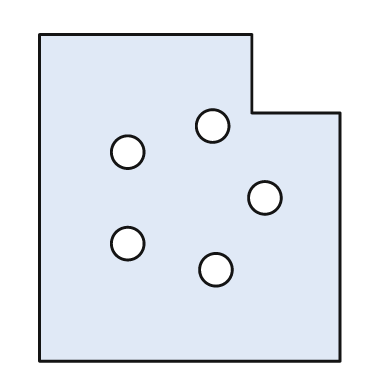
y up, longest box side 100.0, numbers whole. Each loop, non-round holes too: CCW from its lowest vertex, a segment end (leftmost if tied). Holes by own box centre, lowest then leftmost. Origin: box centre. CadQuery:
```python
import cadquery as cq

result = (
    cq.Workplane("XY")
    .moveTo(-46.0, -50.0)
    .lineTo(46.0, -50.0)
    .lineTo(46.0, 26.0)
    .lineTo(19.0, 26.0)
    .lineTo(19.0, 50.0)
    .lineTo(-46.0, 50.0)
    .close()
    .moveTo(8.0, -22.0)
    .circle(5.0)
    .moveTo(-19.0, -14.0)
    .circle(5.0)
    .moveTo(23.0, 0.0)
    .circle(5.0)
    .moveTo(-19.0, 14.0)
    .circle(5.0)
    .moveTo(7.0, 22.0)
    .circle(5.0)
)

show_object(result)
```